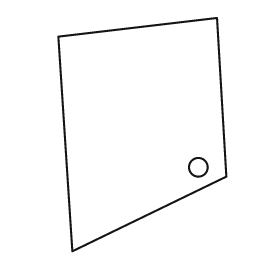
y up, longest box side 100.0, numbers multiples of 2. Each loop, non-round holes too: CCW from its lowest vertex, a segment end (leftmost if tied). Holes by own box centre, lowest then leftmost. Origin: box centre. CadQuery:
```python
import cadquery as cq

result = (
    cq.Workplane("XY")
    .moveTo(-30.0, -50.0)
    .lineTo(36.0, -18.0)
    .lineTo(32.0, 50.0)
    .lineTo(-36.0, 42.0)
    .close()
    .moveTo(24.0, -14.0)
    .circle(4.0)
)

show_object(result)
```